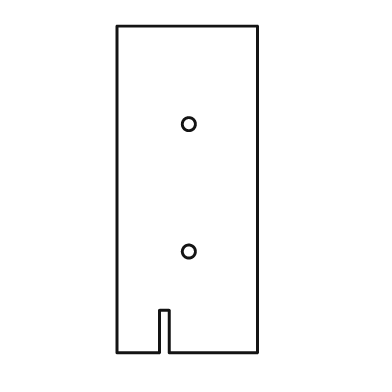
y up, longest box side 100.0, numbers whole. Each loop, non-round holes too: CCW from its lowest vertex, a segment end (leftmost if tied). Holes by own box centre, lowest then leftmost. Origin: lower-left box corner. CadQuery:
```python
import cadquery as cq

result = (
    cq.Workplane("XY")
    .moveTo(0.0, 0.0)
    .lineTo(13.0, 0.0)
    .lineTo(13.0, 13.0)
    .lineTo(16.0, 13.0)
    .lineTo(16.0, 0.0)
    .lineTo(43.0, 0.0)
    .lineTo(43.0, 100.0)
    .lineTo(0.0, 100.0)
    .close()
    .moveTo(22.0, 31.0)
    .circle(2.0)
    .moveTo(22.0, 70.0)
    .circle(2.0)
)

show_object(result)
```